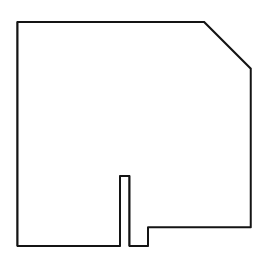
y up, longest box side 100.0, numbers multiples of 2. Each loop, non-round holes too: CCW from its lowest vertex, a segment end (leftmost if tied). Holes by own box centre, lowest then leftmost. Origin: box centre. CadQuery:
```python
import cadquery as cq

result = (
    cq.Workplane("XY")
    .moveTo(-50.0, -48.0)
    .lineTo(-6.0, -48.0)
    .lineTo(-6.0, -18.0)
    .lineTo(-2.0, -18.0)
    .lineTo(-2.0, -48.0)
    .lineTo(6.0, -48.0)
    .lineTo(6.0, -40.0)
    .lineTo(50.0, -40.0)
    .lineTo(50.0, 28.0)
    .lineTo(30.0, 48.0)
    .lineTo(-50.0, 48.0)
    .close()
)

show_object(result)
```